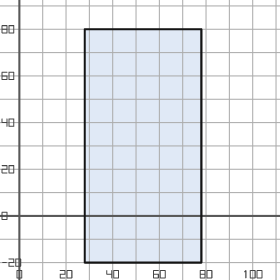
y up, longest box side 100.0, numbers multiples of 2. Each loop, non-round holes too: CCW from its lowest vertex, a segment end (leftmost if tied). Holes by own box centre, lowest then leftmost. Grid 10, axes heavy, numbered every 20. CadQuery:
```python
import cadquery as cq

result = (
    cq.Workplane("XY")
    .moveTo(28.0, -20.0)
    .lineTo(78.0, -20.0)
    .lineTo(78.0, 80.0)
    .lineTo(28.0, 80.0)
    .close()
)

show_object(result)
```